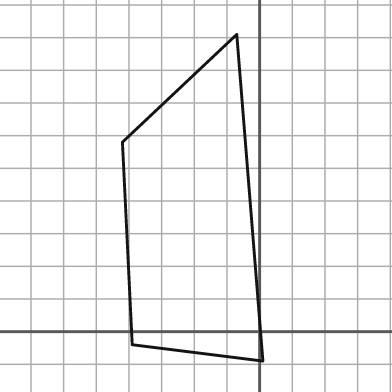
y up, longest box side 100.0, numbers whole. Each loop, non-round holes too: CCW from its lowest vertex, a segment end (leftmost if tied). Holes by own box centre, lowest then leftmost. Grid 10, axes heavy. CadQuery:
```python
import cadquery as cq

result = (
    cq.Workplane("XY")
    .moveTo(1.0, -9.0)
    .lineTo(-7.0, 91.0)
    .lineTo(-42.0, 58.0)
    .lineTo(-39.0, -4.0)
    .close()
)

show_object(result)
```